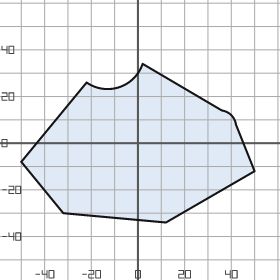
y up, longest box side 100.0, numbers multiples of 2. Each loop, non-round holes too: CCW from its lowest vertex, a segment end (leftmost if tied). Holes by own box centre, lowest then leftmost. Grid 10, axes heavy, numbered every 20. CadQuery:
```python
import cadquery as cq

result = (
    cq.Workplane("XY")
    .moveTo(12.0, -34.0)
    .lineTo(50.0, -12.0)
    .lineTo(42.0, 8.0)
    .threePointArc((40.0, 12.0), (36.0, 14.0))
    .lineTo(2.0, 34.0)
    .threePointArc((-8.0, 24.0), (-22.0, 26.0))
    .lineTo(-50.0, -8.0)
    .lineTo(-32.0, -30.0)
    .close()
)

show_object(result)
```